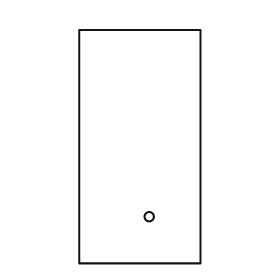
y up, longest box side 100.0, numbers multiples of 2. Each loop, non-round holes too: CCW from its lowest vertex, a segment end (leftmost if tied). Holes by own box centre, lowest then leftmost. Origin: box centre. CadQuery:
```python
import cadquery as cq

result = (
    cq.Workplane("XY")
    .moveTo(-26.0, -50.0)
    .lineTo(26.0, -50.0)
    .lineTo(26.0, 50.0)
    .lineTo(-26.0, 50.0)
    .close()
    .moveTo(4.0, -30.0)
    .circle(2.0)
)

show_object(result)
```